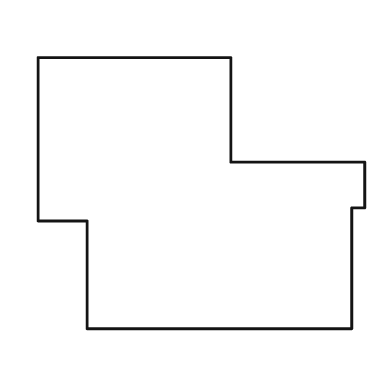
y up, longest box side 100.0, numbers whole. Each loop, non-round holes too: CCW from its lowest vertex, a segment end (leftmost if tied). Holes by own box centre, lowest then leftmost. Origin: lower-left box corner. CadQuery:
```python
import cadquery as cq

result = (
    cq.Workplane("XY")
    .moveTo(15.0, 0.0)
    .lineTo(96.0, 0.0)
    .lineTo(96.0, 37.0)
    .lineTo(100.0, 37.0)
    .lineTo(100.0, 51.0)
    .lineTo(59.0, 51.0)
    .lineTo(59.0, 83.0)
    .lineTo(0.0, 83.0)
    .lineTo(0.0, 33.0)
    .lineTo(15.0, 33.0)
    .close()
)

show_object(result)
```